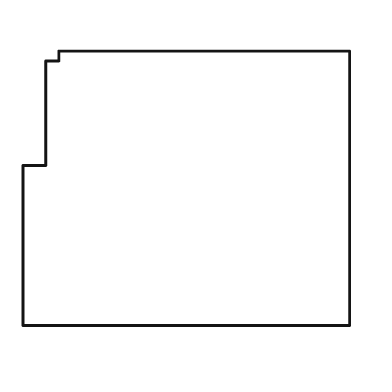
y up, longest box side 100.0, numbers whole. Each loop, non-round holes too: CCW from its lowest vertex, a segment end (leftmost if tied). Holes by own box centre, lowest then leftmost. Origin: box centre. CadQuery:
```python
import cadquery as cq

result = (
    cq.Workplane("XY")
    .moveTo(-50.0, -42.0)
    .lineTo(50.0, -42.0)
    .lineTo(50.0, 42.0)
    .lineTo(-39.0, 42.0)
    .lineTo(-39.0, 39.0)
    .lineTo(-43.0, 39.0)
    .lineTo(-43.0, 7.0)
    .lineTo(-50.0, 7.0)
    .close()
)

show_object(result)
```